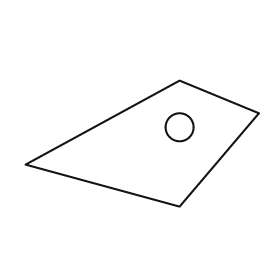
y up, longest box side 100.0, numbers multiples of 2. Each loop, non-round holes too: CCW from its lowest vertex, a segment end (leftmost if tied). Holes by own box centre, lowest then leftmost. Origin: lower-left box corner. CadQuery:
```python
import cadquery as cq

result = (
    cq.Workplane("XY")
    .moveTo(66.0, 0.0)
    .lineTo(100.0, 40.0)
    .lineTo(66.0, 54.0)
    .lineTo(0.0, 18.0)
    .close()
    .moveTo(66.0, 34.0)
    .circle(6.0)
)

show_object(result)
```